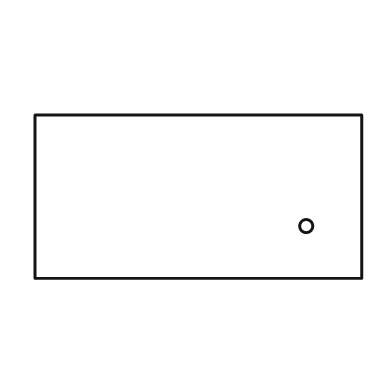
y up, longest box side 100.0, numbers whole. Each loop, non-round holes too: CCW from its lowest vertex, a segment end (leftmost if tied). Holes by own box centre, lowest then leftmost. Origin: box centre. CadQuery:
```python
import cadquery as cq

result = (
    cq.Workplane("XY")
    .moveTo(-50.0, -25.0)
    .lineTo(50.0, -25.0)
    .lineTo(50.0, 25.0)
    .lineTo(-50.0, 25.0)
    .close()
    .moveTo(33.0, -9.0)
    .circle(2.0)
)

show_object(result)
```